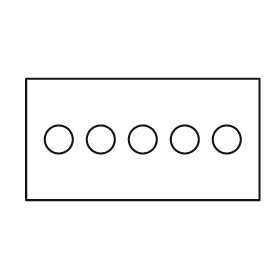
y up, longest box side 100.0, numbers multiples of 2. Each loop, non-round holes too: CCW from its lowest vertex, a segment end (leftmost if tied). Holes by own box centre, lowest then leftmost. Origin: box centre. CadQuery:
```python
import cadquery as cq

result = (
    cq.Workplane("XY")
    .moveTo(-50.0, -26.0)
    .lineTo(50.0, -26.0)
    .lineTo(50.0, 26.0)
    .lineTo(-50.0, 26.0)
    .close()
    .moveTo(-36.0, 0.0)
    .circle(6.0)
    .moveTo(-18.0, 0.0)
    .circle(6.0)
    .moveTo(0.0, 0.0)
    .circle(6.0)
    .moveTo(18.0, 0.0)
    .circle(6.0)
    .moveTo(36.0, 0.0)
    .circle(6.0)
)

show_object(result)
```